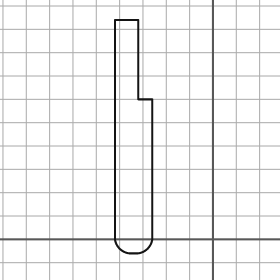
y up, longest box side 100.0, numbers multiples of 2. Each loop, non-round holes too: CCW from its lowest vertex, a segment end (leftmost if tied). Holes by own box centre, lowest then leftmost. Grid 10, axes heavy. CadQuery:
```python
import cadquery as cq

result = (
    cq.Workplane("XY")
    .moveTo(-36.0, -6.0)
    .lineTo(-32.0, -6.0)
    .threePointArc((-28.0, -4.0), (-26.0, 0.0))
    .lineTo(-26.0, 60.0)
    .lineTo(-32.0, 60.0)
    .lineTo(-32.0, 94.0)
    .lineTo(-42.0, 94.0)
    .lineTo(-42.0, 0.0)
    .threePointArc((-40.0, -4.0), (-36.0, -6.0))
    .close()
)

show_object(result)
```